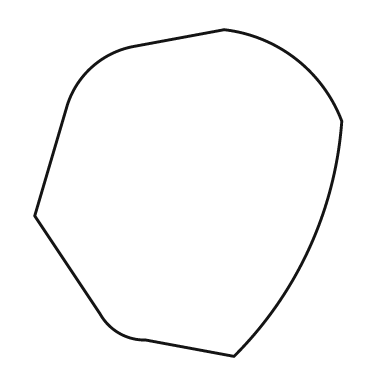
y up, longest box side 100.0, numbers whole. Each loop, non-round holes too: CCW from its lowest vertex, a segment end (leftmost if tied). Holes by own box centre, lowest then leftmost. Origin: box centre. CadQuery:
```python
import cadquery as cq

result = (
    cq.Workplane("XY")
    .moveTo(14.0, -50.0)
    .threePointArc((37.0, -17.0), (47.0, 22.0))
    .threePointArc((33.0, 41.0), (11.0, 50.0))
    .lineTo(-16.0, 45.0)
    .threePointArc((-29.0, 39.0), (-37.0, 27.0))
    .lineTo(-47.0, -7.0)
    .lineTo(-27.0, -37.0)
    .threePointArc((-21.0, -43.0), (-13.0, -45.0))
    .close()
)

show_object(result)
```